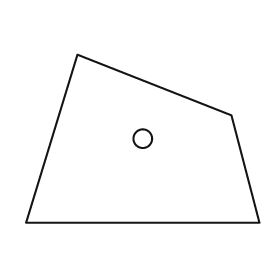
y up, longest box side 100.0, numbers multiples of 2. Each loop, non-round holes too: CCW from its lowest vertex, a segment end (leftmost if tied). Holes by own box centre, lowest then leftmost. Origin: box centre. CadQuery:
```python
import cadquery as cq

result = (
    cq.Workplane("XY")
    .moveTo(-50.0, -36.0)
    .lineTo(50.0, -36.0)
    .lineTo(38.0, 10.0)
    .lineTo(-28.0, 36.0)
    .close()
    .moveTo(0.0, 0.0)
    .circle(4.0)
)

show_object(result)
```